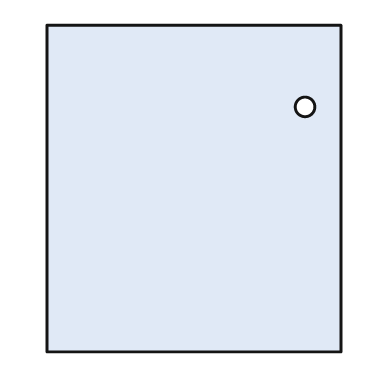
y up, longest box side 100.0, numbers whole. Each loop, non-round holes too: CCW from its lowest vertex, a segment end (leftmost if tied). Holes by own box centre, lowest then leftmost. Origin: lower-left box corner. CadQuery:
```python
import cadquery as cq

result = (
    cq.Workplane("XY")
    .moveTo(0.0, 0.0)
    .lineTo(90.0, 0.0)
    .lineTo(90.0, 100.0)
    .lineTo(0.0, 100.0)
    .close()
    .moveTo(79.0, 75.0)
    .circle(3.0)
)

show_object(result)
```